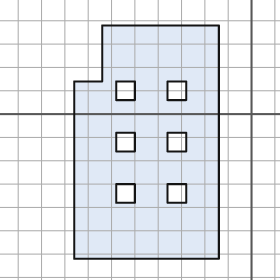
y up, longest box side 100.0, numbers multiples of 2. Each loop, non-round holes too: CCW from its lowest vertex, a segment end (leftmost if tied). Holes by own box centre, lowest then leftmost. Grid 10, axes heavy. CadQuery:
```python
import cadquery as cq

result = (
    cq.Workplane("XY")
    .moveTo(-76.0, -62.0)
    .lineTo(-14.0, -62.0)
    .lineTo(-14.0, 38.0)
    .lineTo(-64.0, 38.0)
    .lineTo(-64.0, 14.0)
    .lineTo(-76.0, 14.0)
    .close()
    .moveTo(-58.0, -38.0)
    .lineTo(-50.0, -38.0)
    .lineTo(-50.0, -30.0)
    .lineTo(-58.0, -30.0)
    .close()
    .moveTo(-36.0, -38.0)
    .lineTo(-28.0, -38.0)
    .lineTo(-28.0, -30.0)
    .lineTo(-36.0, -30.0)
    .close()
    .moveTo(-58.0, -16.0)
    .lineTo(-50.0, -16.0)
    .lineTo(-50.0, -8.0)
    .lineTo(-58.0, -8.0)
    .close()
    .moveTo(-36.0, -16.0)
    .lineTo(-28.0, -16.0)
    .lineTo(-28.0, -8.0)
    .lineTo(-36.0, -8.0)
    .close()
    .moveTo(-58.0, 6.0)
    .lineTo(-50.0, 6.0)
    .lineTo(-50.0, 14.0)
    .lineTo(-58.0, 14.0)
    .close()
    .moveTo(-36.0, 6.0)
    .lineTo(-28.0, 6.0)
    .lineTo(-28.0, 14.0)
    .lineTo(-36.0, 14.0)
    .close()
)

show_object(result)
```